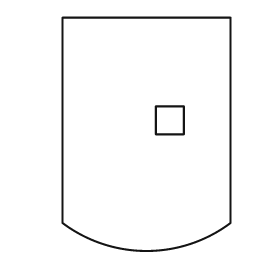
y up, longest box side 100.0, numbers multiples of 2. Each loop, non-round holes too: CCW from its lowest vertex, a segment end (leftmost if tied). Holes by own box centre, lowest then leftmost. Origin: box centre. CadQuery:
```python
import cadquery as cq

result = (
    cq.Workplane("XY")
    .moveTo(-36.0, -38.0)
    .threePointArc((0.0, -50.0), (36.0, -38.0))
    .lineTo(36.0, 50.0)
    .lineTo(-36.0, 50.0)
    .close()
    .moveTo(4.0, 0.0)
    .lineTo(16.0, 0.0)
    .lineTo(16.0, 12.0)
    .lineTo(4.0, 12.0)
    .close()
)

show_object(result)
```